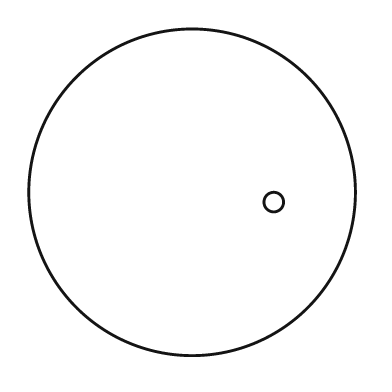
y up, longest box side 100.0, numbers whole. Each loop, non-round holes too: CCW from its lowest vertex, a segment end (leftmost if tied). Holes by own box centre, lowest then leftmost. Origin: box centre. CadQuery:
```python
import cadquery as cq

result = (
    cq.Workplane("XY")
    .moveTo(0.0, 0.0)
    .circle(50.0)
    .moveTo(25.0, -3.0)
    .circle(3.0)
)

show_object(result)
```